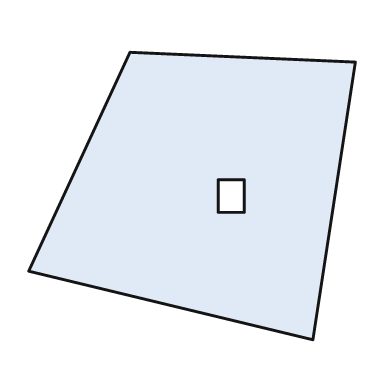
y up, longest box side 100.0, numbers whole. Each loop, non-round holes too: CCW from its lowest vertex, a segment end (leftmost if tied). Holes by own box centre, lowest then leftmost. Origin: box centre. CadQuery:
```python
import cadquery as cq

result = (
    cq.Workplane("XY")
    .moveTo(37.0, -44.0)
    .lineTo(50.0, 41.0)
    .lineTo(-19.0, 44.0)
    .lineTo(-50.0, -23.0)
    .close()
    .moveTo(8.0, -5.0)
    .lineTo(16.0, -5.0)
    .lineTo(16.0, 5.0)
    .lineTo(8.0, 5.0)
    .close()
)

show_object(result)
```